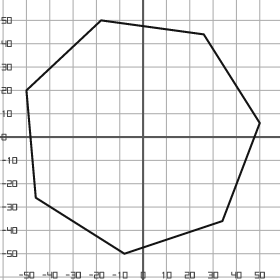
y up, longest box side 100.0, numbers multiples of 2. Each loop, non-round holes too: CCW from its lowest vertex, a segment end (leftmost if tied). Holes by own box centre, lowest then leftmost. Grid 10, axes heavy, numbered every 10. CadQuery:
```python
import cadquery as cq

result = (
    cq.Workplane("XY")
    .moveTo(-8.0, -50.0)
    .lineTo(34.0, -36.0)
    .lineTo(50.0, 6.0)
    .lineTo(26.0, 44.0)
    .lineTo(-18.0, 50.0)
    .lineTo(-50.0, 20.0)
    .lineTo(-46.0, -26.0)
    .close()
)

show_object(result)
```